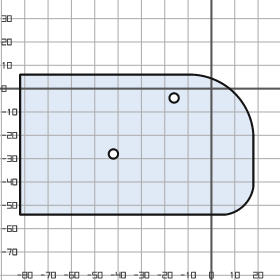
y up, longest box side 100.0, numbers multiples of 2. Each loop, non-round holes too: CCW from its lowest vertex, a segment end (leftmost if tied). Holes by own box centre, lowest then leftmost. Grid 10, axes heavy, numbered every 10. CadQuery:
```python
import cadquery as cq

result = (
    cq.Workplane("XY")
    .moveTo(-82.0, -54.0)
    .lineTo(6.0, -54.0)
    .threePointArc((14.0, -50.0), (18.0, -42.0))
    .lineTo(18.0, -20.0)
    .threePointArc((10.0, -2.0), (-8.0, 6.0))
    .lineTo(-82.0, 6.0)
    .close()
    .moveTo(-42.0, -28.0)
    .circle(2.0)
    .moveTo(-16.0, -4.0)
    .circle(2.0)
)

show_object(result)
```